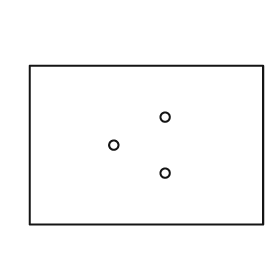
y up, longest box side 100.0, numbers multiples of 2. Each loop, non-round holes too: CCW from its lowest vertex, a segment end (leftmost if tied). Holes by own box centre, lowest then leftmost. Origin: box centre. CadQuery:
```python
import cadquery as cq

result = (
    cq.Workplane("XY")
    .moveTo(-50.0, -34.0)
    .lineTo(50.0, -34.0)
    .lineTo(50.0, 34.0)
    .lineTo(-50.0, 34.0)
    .close()
    .moveTo(8.0, -12.0)
    .circle(2.0)
    .moveTo(-14.0, 0.0)
    .circle(2.0)
    .moveTo(8.0, 12.0)
    .circle(2.0)
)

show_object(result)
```